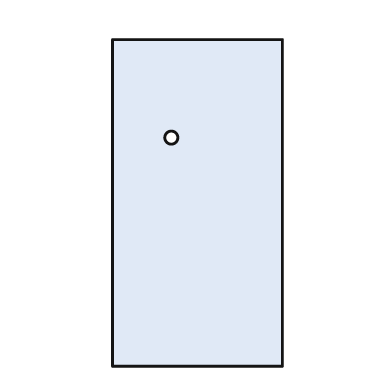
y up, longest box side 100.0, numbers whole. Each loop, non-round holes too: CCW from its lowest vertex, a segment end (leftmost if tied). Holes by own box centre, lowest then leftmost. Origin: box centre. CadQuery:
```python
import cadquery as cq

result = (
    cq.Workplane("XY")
    .moveTo(-26.0, -50.0)
    .lineTo(26.0, -50.0)
    .lineTo(26.0, 50.0)
    .lineTo(-26.0, 50.0)
    .close()
    .moveTo(-8.0, 20.0)
    .circle(2.0)
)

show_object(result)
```